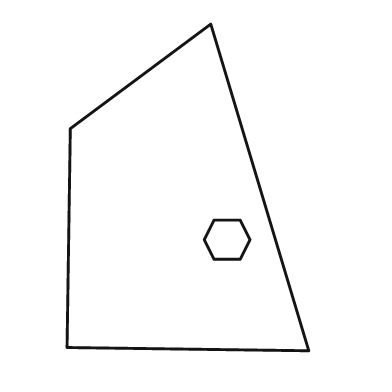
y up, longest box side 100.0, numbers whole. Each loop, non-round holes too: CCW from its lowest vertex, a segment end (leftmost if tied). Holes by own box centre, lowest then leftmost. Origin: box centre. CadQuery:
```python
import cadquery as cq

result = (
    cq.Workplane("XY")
    .moveTo(37.0, -50.0)
    .lineTo(7.0, 50.0)
    .lineTo(-36.0, 18.0)
    .lineTo(-37.0, -49.0)
    .close()
    .moveTo(8.0, -22.0)
    .lineTo(16.0, -22.0)
    .lineTo(19.0, -16.0)
    .lineTo(16.0, -10.0)
    .lineTo(8.0, -10.0)
    .lineTo(5.0, -16.0)
    .close()
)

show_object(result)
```